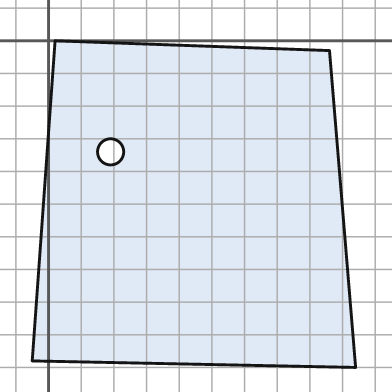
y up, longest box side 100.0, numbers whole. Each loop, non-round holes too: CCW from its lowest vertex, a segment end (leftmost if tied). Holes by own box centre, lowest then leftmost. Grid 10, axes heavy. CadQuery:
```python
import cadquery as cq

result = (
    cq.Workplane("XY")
    .moveTo(94.0, -100.0)
    .lineTo(86.0, -3.0)
    .lineTo(2.0, 0.0)
    .lineTo(-5.0, -98.0)
    .close()
    .moveTo(19.0, -34.0)
    .circle(4.0)
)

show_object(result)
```